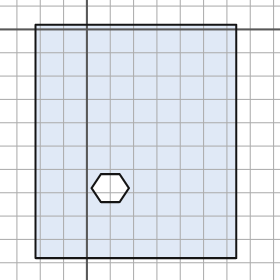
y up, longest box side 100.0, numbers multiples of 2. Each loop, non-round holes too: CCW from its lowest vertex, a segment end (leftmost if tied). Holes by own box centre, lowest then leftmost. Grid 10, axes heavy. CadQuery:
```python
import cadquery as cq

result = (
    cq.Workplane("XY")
    .moveTo(-22.0, -98.0)
    .lineTo(64.0, -98.0)
    .lineTo(64.0, 2.0)
    .lineTo(-22.0, 2.0)
    .close()
    .moveTo(6.0, -74.0)
    .lineTo(14.0, -74.0)
    .lineTo(18.0, -68.0)
    .lineTo(14.0, -62.0)
    .lineTo(6.0, -62.0)
    .lineTo(2.0, -68.0)
    .close()
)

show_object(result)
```